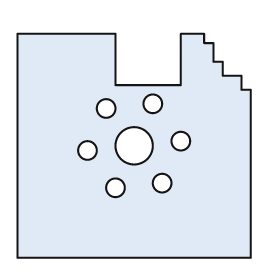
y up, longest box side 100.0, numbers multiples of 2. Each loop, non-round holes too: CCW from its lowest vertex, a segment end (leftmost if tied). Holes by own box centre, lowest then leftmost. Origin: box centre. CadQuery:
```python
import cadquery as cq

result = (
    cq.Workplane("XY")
    .moveTo(-50.0, -48.0)
    .lineTo(50.0, -48.0)
    .lineTo(50.0, 24.0)
    .lineTo(46.0, 24.0)
    .lineTo(46.0, 30.0)
    .lineTo(38.0, 30.0)
    .lineTo(38.0, 36.0)
    .lineTo(34.0, 36.0)
    .lineTo(34.0, 44.0)
    .lineTo(30.0, 44.0)
    .lineTo(30.0, 48.0)
    .lineTo(20.0, 48.0)
    .lineTo(20.0, 26.0)
    .lineTo(-8.0, 26.0)
    .lineTo(-8.0, 48.0)
    .lineTo(-50.0, 48.0)
    .close()
    .moveTo(-8.0, -18.0)
    .circle(4.0)
    .moveTo(12.0, -16.0)
    .circle(4.0)
    .moveTo(-20.0, -2.0)
    .circle(4.0)
    .moveTo(0.0, 0.0)
    .circle(8.0)
    .moveTo(20.0, 2.0)
    .circle(4.0)
    .moveTo(-12.0, 16.0)
    .circle(4.0)
    .moveTo(8.0, 18.0)
    .circle(4.0)
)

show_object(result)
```